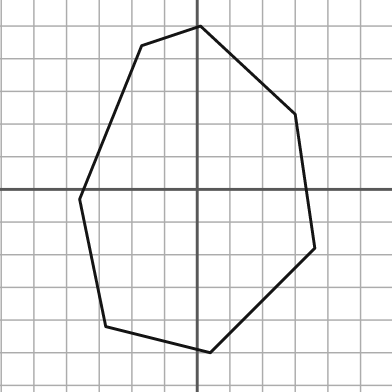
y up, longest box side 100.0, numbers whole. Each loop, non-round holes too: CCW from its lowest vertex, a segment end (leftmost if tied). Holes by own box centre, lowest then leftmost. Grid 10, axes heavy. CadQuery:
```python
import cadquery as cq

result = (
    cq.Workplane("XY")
    .moveTo(4.0, -50.0)
    .lineTo(36.0, -18.0)
    .lineTo(30.0, 23.0)
    .lineTo(1.0, 50.0)
    .lineTo(-17.0, 44.0)
    .lineTo(-36.0, -3.0)
    .lineTo(-28.0, -42.0)
    .close()
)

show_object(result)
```